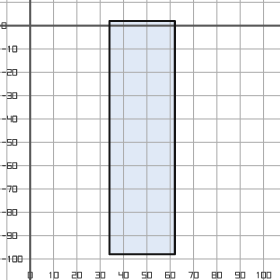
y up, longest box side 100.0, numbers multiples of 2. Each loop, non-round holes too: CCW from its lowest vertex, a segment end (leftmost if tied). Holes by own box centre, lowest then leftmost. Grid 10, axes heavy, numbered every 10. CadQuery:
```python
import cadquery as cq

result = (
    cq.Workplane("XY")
    .moveTo(34.0, -98.0)
    .lineTo(62.0, -98.0)
    .lineTo(62.0, 2.0)
    .lineTo(34.0, 2.0)
    .close()
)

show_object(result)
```